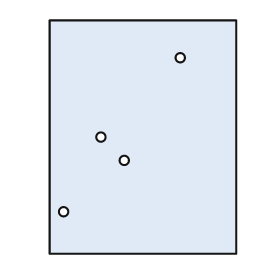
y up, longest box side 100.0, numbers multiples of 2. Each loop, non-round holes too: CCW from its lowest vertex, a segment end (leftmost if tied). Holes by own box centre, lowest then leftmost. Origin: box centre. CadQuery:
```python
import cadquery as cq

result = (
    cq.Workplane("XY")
    .moveTo(-40.0, -50.0)
    .lineTo(40.0, -50.0)
    .lineTo(40.0, 50.0)
    .lineTo(-40.0, 50.0)
    .close()
    .moveTo(-34.0, -32.0)
    .circle(2.0)
    .moveTo(-8.0, -10.0)
    .circle(2.0)
    .moveTo(-18.0, 0.0)
    .circle(2.0)
    .moveTo(16.0, 34.0)
    .circle(2.0)
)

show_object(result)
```